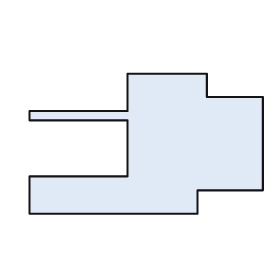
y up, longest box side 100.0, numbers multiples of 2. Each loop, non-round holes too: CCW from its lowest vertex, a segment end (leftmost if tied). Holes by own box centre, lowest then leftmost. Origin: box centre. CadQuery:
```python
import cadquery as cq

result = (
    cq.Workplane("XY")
    .moveTo(-50.0, -30.0)
    .lineTo(22.0, -30.0)
    .lineTo(22.0, -20.0)
    .lineTo(50.0, -20.0)
    .lineTo(50.0, 20.0)
    .lineTo(26.0, 20.0)
    .lineTo(26.0, 30.0)
    .lineTo(-8.0, 30.0)
    .lineTo(-8.0, 14.0)
    .lineTo(-50.0, 14.0)
    .lineTo(-50.0, 10.0)
    .lineTo(-8.0, 10.0)
    .lineTo(-8.0, -14.0)
    .lineTo(-50.0, -14.0)
    .close()
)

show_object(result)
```